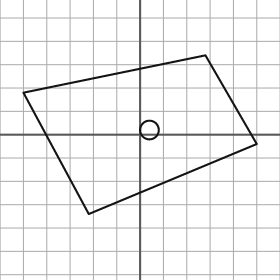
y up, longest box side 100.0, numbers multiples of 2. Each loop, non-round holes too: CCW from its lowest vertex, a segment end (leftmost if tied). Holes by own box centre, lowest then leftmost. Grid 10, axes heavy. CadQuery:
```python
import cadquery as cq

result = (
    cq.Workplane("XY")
    .moveTo(-22.0, -34.0)
    .lineTo(50.0, -4.0)
    .lineTo(28.0, 34.0)
    .lineTo(-50.0, 18.0)
    .close()
    .moveTo(4.0, 2.0)
    .circle(4.0)
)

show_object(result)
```